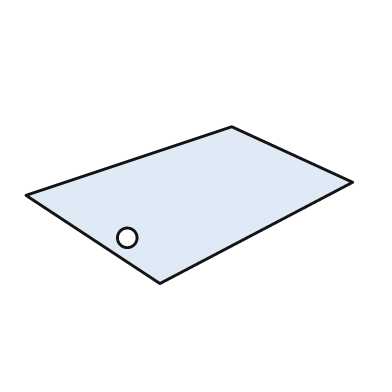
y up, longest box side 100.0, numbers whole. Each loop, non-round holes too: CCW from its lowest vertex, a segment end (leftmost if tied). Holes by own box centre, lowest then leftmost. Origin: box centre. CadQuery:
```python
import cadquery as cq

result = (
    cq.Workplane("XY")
    .moveTo(-9.0, -24.0)
    .lineTo(50.0, 7.0)
    .lineTo(13.0, 24.0)
    .lineTo(-50.0, 3.0)
    .close()
    .moveTo(-19.0, -10.0)
    .circle(3.0)
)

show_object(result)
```